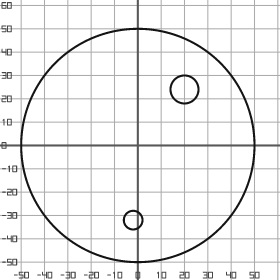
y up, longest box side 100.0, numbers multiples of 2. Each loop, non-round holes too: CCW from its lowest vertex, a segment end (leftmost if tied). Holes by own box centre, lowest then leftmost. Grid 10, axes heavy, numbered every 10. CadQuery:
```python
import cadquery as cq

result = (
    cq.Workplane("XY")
    .moveTo(0.0, 0.0)
    .circle(50.0)
    .moveTo(-2.0, -32.0)
    .circle(4.0)
    .moveTo(20.0, 24.0)
    .circle(6.0)
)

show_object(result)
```